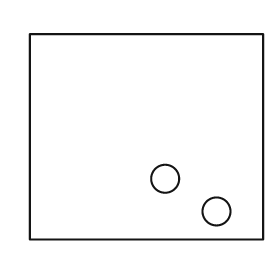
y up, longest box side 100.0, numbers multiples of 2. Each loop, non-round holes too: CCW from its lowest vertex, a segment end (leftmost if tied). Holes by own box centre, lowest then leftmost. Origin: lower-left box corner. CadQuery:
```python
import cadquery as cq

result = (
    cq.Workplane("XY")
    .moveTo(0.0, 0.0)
    .lineTo(100.0, 0.0)
    .lineTo(100.0, 88.0)
    .lineTo(0.0, 88.0)
    .close()
    .moveTo(80.0, 12.0)
    .circle(6.0)
    .moveTo(58.0, 26.0)
    .circle(6.0)
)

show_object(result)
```